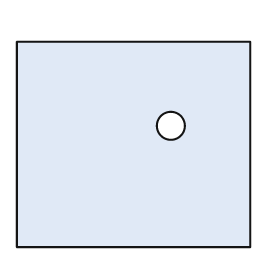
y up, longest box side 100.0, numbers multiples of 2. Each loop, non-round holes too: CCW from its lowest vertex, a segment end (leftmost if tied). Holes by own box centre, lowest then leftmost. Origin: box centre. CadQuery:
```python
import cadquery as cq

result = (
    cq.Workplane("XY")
    .moveTo(-50.0, -44.0)
    .lineTo(50.0, -44.0)
    .lineTo(50.0, 44.0)
    .lineTo(-50.0, 44.0)
    .close()
    .moveTo(16.0, 8.0)
    .circle(6.0)
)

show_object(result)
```